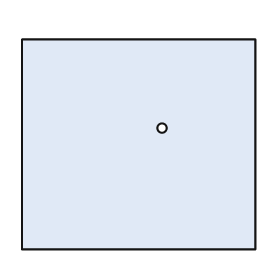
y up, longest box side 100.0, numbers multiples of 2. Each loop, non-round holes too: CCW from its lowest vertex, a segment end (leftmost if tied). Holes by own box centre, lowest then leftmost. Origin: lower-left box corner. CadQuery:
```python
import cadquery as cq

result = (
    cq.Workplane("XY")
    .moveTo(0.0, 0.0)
    .lineTo(100.0, 0.0)
    .lineTo(100.0, 90.0)
    .lineTo(0.0, 90.0)
    .close()
    .moveTo(60.0, 52.0)
    .circle(2.0)
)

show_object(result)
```